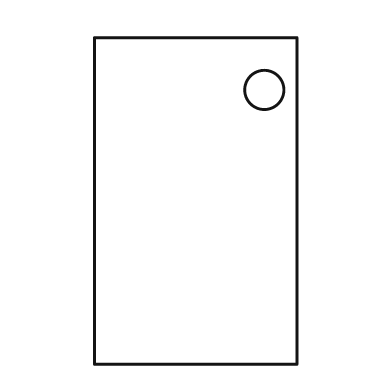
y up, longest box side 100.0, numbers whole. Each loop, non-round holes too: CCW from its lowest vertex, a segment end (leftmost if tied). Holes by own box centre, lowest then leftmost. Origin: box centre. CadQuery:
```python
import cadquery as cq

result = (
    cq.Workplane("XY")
    .moveTo(-31.0, -50.0)
    .lineTo(31.0, -50.0)
    .lineTo(31.0, 50.0)
    .lineTo(-31.0, 50.0)
    .close()
    .moveTo(21.0, 34.0)
    .circle(6.0)
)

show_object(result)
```